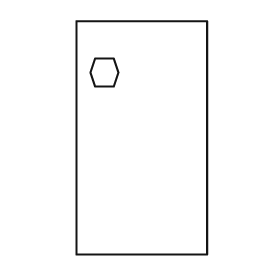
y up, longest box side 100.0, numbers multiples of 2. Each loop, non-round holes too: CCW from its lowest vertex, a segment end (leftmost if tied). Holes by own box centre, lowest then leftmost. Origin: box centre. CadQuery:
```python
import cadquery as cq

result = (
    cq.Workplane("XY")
    .moveTo(-28.0, -50.0)
    .lineTo(28.0, -50.0)
    .lineTo(28.0, 50.0)
    .lineTo(-28.0, 50.0)
    .close()
    .moveTo(-20.0, 22.0)
    .lineTo(-12.0, 22.0)
    .lineTo(-10.0, 28.0)
    .lineTo(-12.0, 34.0)
    .lineTo(-20.0, 34.0)
    .lineTo(-22.0, 28.0)
    .close()
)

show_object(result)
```